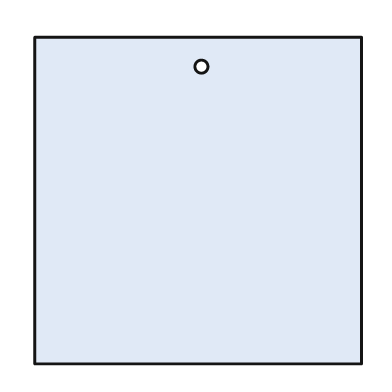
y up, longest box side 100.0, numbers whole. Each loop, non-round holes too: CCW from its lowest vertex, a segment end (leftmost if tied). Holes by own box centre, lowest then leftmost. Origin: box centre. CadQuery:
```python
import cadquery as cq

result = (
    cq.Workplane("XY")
    .moveTo(-50.0, -50.0)
    .lineTo(50.0, -50.0)
    .lineTo(50.0, 50.0)
    .lineTo(-50.0, 50.0)
    .close()
    .moveTo(1.0, 41.0)
    .circle(2.0)
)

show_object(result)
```